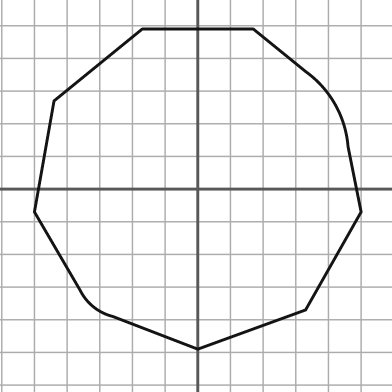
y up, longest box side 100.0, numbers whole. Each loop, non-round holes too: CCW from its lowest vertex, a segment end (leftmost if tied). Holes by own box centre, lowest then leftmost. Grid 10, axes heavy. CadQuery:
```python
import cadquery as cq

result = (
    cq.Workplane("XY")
    .moveTo(0.0, -49.0)
    .lineTo(33.0, -37.0)
    .lineTo(50.0, -7.0)
    .lineTo(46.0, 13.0)
    .threePointArc((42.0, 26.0), (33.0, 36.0))
    .lineTo(17.0, 49.0)
    .lineTo(-17.0, 49.0)
    .lineTo(-44.0, 27.0)
    .lineTo(-50.0, -7.0)
    .lineTo(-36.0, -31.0)
    .threePointArc((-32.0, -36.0), (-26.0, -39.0))
    .close()
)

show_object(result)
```